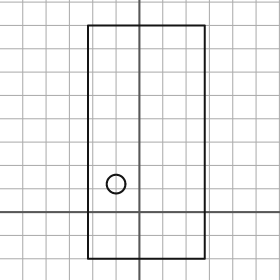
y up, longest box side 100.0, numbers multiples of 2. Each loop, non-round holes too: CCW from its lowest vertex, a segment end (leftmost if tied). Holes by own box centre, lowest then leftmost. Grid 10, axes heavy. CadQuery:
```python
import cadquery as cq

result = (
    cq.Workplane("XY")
    .moveTo(-22.0, -20.0)
    .lineTo(28.0, -20.0)
    .lineTo(28.0, 80.0)
    .lineTo(-22.0, 80.0)
    .close()
    .moveTo(-10.0, 12.0)
    .circle(4.0)
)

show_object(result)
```